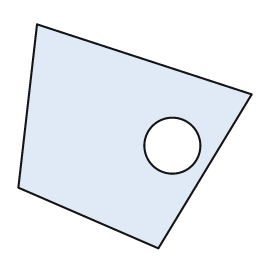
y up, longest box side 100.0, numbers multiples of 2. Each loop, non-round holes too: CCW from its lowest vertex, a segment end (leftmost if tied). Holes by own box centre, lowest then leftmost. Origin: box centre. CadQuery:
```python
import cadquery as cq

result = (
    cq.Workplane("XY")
    .moveTo(10.0, -48.0)
    .lineTo(50.0, 18.0)
    .lineTo(-42.0, 48.0)
    .lineTo(-50.0, -22.0)
    .close()
    .moveTo(16.0, -4.0)
    .circle(12.0)
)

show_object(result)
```